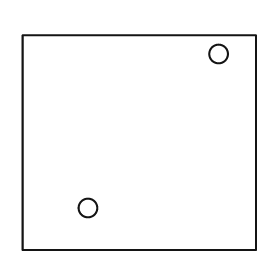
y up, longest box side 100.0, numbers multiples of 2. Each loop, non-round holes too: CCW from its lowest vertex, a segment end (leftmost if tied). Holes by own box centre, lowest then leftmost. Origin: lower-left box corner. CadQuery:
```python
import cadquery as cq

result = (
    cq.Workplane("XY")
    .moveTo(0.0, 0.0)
    .lineTo(100.0, 0.0)
    .lineTo(100.0, 92.0)
    .lineTo(0.0, 92.0)
    .close()
    .moveTo(28.0, 18.0)
    .circle(4.0)
    .moveTo(84.0, 84.0)
    .circle(4.0)
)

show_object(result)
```